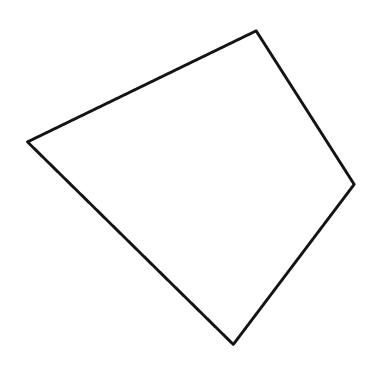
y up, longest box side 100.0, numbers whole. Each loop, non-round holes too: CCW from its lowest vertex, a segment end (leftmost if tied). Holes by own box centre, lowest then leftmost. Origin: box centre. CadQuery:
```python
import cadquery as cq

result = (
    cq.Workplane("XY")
    .moveTo(13.0, -48.0)
    .lineTo(50.0, 1.0)
    .lineTo(20.0, 48.0)
    .lineTo(-50.0, 14.0)
    .close()
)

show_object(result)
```